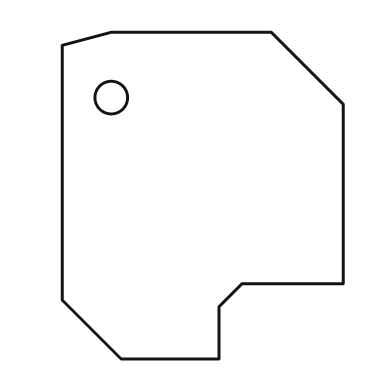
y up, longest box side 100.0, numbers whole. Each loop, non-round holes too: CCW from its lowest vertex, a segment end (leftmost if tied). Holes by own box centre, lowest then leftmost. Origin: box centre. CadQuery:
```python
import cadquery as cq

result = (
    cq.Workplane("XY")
    .moveTo(-25.0, -50.0)
    .lineTo(5.0, -50.0)
    .lineTo(5.0, -34.0)
    .lineTo(12.0, -27.0)
    .lineTo(43.0, -27.0)
    .lineTo(43.0, 28.0)
    .lineTo(21.0, 50.0)
    .lineTo(-28.0, 50.0)
    .lineTo(-43.0, 46.0)
    .lineTo(-43.0, -32.0)
    .close()
    .moveTo(-28.0, 30.0)
    .circle(5.0)
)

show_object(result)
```